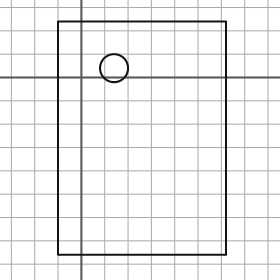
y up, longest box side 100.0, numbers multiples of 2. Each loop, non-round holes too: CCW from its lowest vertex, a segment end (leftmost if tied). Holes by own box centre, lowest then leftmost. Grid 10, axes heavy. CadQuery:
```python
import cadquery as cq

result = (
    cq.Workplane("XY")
    .moveTo(-10.0, -76.0)
    .lineTo(62.0, -76.0)
    .lineTo(62.0, 24.0)
    .lineTo(-10.0, 24.0)
    .close()
    .moveTo(14.0, 4.0)
    .circle(6.0)
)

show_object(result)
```